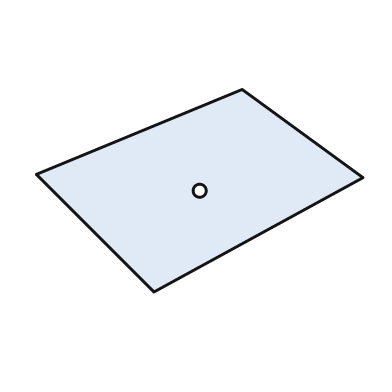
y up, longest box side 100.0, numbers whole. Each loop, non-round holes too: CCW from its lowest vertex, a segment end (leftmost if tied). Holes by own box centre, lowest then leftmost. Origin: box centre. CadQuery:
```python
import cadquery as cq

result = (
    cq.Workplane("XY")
    .moveTo(-14.0, -31.0)
    .lineTo(50.0, 4.0)
    .lineTo(13.0, 31.0)
    .lineTo(-50.0, 5.0)
    .close()
    .moveTo(0.0, 0.0)
    .circle(2.0)
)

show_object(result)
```